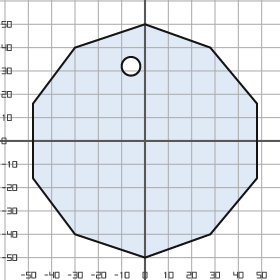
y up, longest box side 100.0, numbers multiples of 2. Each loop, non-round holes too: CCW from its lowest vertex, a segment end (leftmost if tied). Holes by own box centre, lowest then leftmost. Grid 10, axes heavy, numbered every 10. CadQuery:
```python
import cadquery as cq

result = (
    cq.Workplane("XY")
    .moveTo(0.0, -50.0)
    .lineTo(28.0, -40.0)
    .lineTo(48.0, -16.0)
    .lineTo(48.0, 16.0)
    .lineTo(28.0, 40.0)
    .lineTo(0.0, 50.0)
    .lineTo(-30.0, 40.0)
    .lineTo(-48.0, 16.0)
    .lineTo(-48.0, -16.0)
    .lineTo(-30.0, -40.0)
    .close()
    .moveTo(-6.0, 32.0)
    .circle(4.0)
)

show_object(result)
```